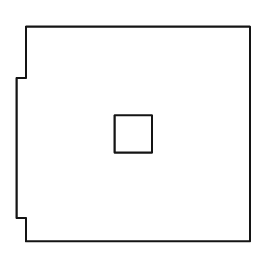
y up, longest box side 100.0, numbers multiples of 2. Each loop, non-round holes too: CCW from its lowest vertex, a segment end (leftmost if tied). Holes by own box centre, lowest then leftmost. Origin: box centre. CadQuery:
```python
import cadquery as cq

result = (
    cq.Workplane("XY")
    .moveTo(-46.0, -46.0)
    .lineTo(50.0, -46.0)
    .lineTo(50.0, 46.0)
    .lineTo(-46.0, 46.0)
    .lineTo(-46.0, 24.0)
    .lineTo(-50.0, 24.0)
    .lineTo(-50.0, -36.0)
    .lineTo(-46.0, -36.0)
    .close()
    .moveTo(-8.0, -8.0)
    .lineTo(8.0, -8.0)
    .lineTo(8.0, 8.0)
    .lineTo(-8.0, 8.0)
    .close()
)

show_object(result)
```